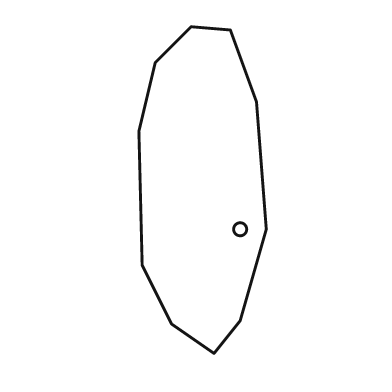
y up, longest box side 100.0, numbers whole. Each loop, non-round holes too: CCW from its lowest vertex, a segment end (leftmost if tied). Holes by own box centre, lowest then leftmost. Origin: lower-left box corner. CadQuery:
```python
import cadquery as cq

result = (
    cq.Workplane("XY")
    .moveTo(23.0, 0.0)
    .lineTo(31.0, 10.0)
    .lineTo(39.0, 38.0)
    .lineTo(36.0, 77.0)
    .lineTo(28.0, 99.0)
    .lineTo(16.0, 100.0)
    .lineTo(5.0, 89.0)
    .lineTo(0.0, 68.0)
    .lineTo(1.0, 27.0)
    .lineTo(10.0, 9.0)
    .close()
    .moveTo(31.0, 38.0)
    .circle(2.0)
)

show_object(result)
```